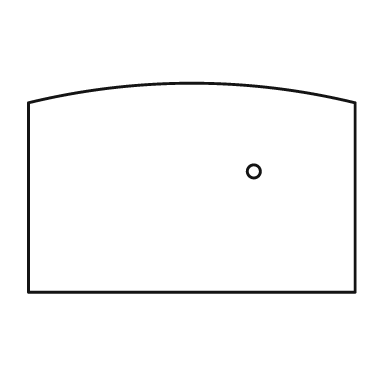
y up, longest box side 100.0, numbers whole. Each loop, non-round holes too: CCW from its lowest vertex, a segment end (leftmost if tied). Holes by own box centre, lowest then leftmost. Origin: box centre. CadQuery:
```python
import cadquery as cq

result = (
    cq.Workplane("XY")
    .moveTo(-50.0, -32.0)
    .lineTo(50.0, -32.0)
    .lineTo(50.0, 26.0)
    .threePointArc((0.0, 32.0), (-50.0, 26.0))
    .close()
    .moveTo(19.0, 5.0)
    .circle(2.0)
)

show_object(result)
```